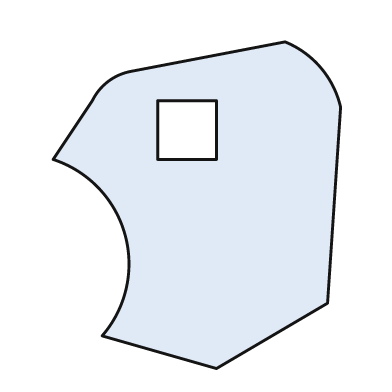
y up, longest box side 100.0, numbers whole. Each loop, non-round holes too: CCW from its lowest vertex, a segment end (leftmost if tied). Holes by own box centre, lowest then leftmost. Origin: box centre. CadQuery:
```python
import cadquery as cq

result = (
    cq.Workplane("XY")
    .moveTo(6.0, -50.0)
    .lineTo(40.0, -30.0)
    .lineTo(44.0, 30.0)
    .threePointArc((38.0, 42.0), (27.0, 50.0))
    .lineTo(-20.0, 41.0)
    .threePointArc((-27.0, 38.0), (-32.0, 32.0))
    .lineTo(-44.0, 14.0)
    .threePointArc((-22.0, -9.0), (-29.0, -40.0))
    .close()
    .moveTo(-12.0, 14.0)
    .lineTo(6.0, 14.0)
    .lineTo(6.0, 32.0)
    .lineTo(-12.0, 32.0)
    .close()
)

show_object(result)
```